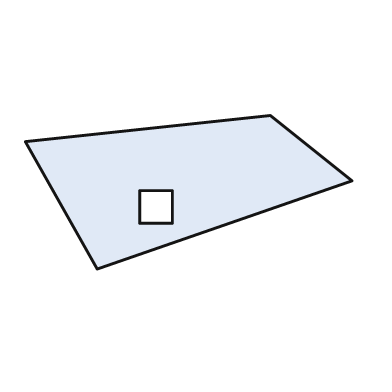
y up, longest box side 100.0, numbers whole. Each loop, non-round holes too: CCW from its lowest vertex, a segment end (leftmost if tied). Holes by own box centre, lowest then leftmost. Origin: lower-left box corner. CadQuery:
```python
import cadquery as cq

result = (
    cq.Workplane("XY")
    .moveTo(22.0, 0.0)
    .lineTo(100.0, 27.0)
    .lineTo(75.0, 47.0)
    .lineTo(0.0, 39.0)
    .close()
    .moveTo(35.0, 14.0)
    .lineTo(45.0, 14.0)
    .lineTo(45.0, 24.0)
    .lineTo(35.0, 24.0)
    .close()
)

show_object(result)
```